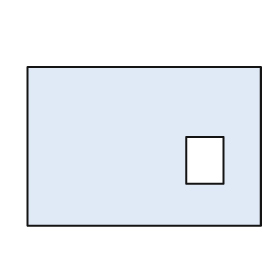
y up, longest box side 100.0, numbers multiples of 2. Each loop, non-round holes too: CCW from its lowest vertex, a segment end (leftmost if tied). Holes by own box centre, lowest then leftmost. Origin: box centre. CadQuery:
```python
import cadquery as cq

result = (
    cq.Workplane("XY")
    .moveTo(-50.0, -34.0)
    .lineTo(50.0, -34.0)
    .lineTo(50.0, 34.0)
    .lineTo(-50.0, 34.0)
    .close()
    .moveTo(18.0, -16.0)
    .lineTo(34.0, -16.0)
    .lineTo(34.0, 4.0)
    .lineTo(18.0, 4.0)
    .close()
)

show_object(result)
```